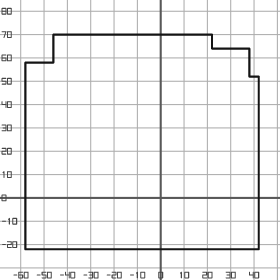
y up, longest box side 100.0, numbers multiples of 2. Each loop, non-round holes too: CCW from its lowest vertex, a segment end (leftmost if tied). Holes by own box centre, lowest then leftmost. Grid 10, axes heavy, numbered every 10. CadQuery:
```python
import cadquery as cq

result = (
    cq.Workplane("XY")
    .moveTo(-58.0, -22.0)
    .lineTo(42.0, -22.0)
    .lineTo(42.0, 52.0)
    .lineTo(38.0, 52.0)
    .lineTo(38.0, 64.0)
    .lineTo(22.0, 64.0)
    .lineTo(22.0, 70.0)
    .lineTo(-46.0, 70.0)
    .lineTo(-46.0, 58.0)
    .lineTo(-58.0, 58.0)
    .close()
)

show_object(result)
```